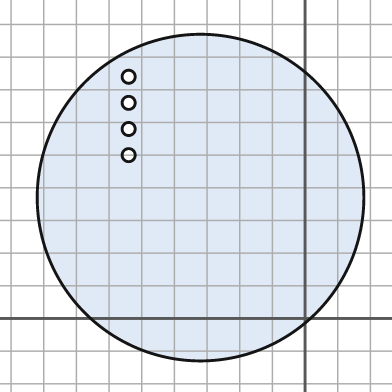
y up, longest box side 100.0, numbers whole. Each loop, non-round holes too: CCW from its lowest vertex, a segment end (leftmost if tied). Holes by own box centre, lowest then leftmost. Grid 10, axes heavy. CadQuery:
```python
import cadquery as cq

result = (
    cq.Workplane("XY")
    .moveTo(-32.0, 37.0)
    .circle(50.0)
    .moveTo(-54.0, 50.0)
    .circle(2.0)
    .moveTo(-54.0, 58.0)
    .circle(2.0)
    .moveTo(-54.0, 66.0)
    .circle(2.0)
    .moveTo(-54.0, 74.0)
    .circle(2.0)
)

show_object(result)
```